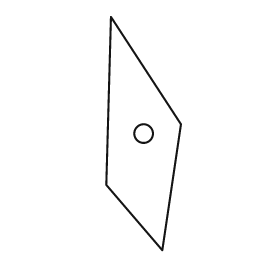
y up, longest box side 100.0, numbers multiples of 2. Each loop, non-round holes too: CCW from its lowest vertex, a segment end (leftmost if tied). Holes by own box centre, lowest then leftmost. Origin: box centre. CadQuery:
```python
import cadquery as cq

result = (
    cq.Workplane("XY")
    .moveTo(8.0, -50.0)
    .lineTo(16.0, 4.0)
    .lineTo(-14.0, 50.0)
    .lineTo(-16.0, -22.0)
    .close()
    .moveTo(0.0, 0.0)
    .circle(4.0)
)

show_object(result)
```